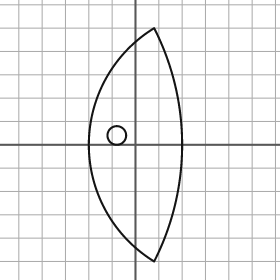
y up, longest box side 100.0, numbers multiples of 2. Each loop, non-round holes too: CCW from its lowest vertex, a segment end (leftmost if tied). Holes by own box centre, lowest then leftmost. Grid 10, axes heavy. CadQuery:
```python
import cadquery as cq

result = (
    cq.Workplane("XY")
    .moveTo(8.0, -50.0)
    .threePointArc((20.0, 0.0), (8.0, 50.0))
    .threePointArc((-20.0, 0.0), (8.0, -50.0))
    .close()
    .moveTo(-8.0, 4.0)
    .circle(4.0)
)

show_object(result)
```